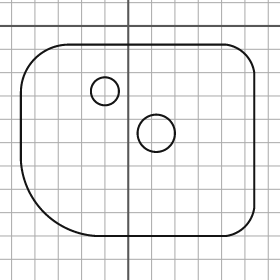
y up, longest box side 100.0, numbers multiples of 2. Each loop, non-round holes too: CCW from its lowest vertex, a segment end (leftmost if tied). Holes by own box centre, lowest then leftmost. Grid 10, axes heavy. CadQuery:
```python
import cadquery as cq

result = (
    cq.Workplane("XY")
    .moveTo(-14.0, -90.0)
    .lineTo(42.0, -90.0)
    .threePointArc((50.0, -86.0), (54.0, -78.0))
    .lineTo(54.0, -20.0)
    .threePointArc((50.0, -12.0), (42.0, -8.0))
    .lineTo(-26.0, -8.0)
    .threePointArc((-40.0, -14.0), (-46.0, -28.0))
    .lineTo(-46.0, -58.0)
    .threePointArc((-36.0, -80.0), (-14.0, -90.0))
    .close()
    .moveTo(12.0, -46.0)
    .circle(8.0)
    .moveTo(-10.0, -28.0)
    .circle(6.0)
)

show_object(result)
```